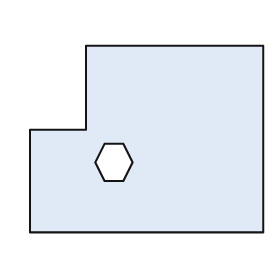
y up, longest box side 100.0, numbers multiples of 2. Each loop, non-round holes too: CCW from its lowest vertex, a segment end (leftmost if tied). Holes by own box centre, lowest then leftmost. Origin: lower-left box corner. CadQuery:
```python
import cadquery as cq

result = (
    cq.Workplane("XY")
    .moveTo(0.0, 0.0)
    .lineTo(100.0, 0.0)
    .lineTo(100.0, 80.0)
    .lineTo(24.0, 80.0)
    .lineTo(24.0, 44.0)
    .lineTo(0.0, 44.0)
    .close()
    .moveTo(32.0, 22.0)
    .lineTo(40.0, 22.0)
    .lineTo(44.0, 30.0)
    .lineTo(40.0, 38.0)
    .lineTo(32.0, 38.0)
    .lineTo(28.0, 30.0)
    .close()
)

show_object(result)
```